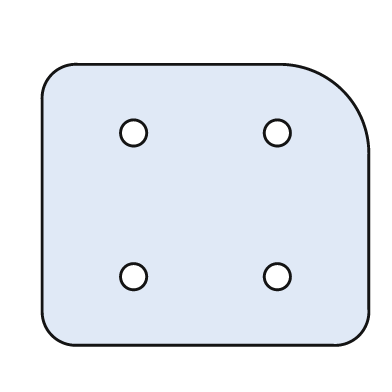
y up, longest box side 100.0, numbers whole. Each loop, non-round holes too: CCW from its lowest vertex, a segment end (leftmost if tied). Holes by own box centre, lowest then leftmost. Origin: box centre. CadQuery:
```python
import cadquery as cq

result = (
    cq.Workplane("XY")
    .moveTo(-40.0, -43.0)
    .lineTo(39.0, -43.0)
    .threePointArc((47.0, -40.0), (50.0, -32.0))
    .lineTo(50.0, 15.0)
    .threePointArc((42.0, 35.0), (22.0, 43.0))
    .lineTo(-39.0, 43.0)
    .threePointArc((-47.0, 40.0), (-50.0, 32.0))
    .lineTo(-50.0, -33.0)
    .threePointArc((-47.0, -40.0), (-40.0, -43.0))
    .close()
    .moveTo(-22.0, -22.0)
    .circle(4.0)
    .moveTo(22.0, -22.0)
    .circle(4.0)
    .moveTo(-22.0, 22.0)
    .circle(4.0)
    .moveTo(22.0, 22.0)
    .circle(4.0)
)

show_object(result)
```